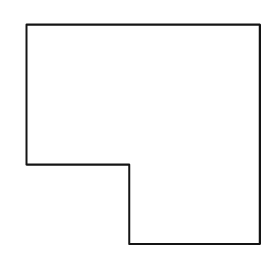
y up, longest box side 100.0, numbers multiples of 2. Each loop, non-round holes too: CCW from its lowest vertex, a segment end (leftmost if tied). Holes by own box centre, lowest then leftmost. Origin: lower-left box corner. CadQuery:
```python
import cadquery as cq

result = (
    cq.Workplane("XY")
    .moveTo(44.0, 0.0)
    .lineTo(100.0, 0.0)
    .lineTo(100.0, 94.0)
    .lineTo(0.0, 94.0)
    .lineTo(0.0, 34.0)
    .lineTo(44.0, 34.0)
    .close()
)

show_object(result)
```